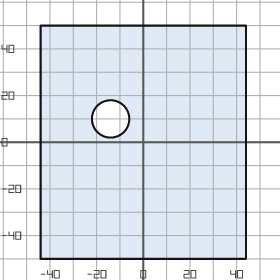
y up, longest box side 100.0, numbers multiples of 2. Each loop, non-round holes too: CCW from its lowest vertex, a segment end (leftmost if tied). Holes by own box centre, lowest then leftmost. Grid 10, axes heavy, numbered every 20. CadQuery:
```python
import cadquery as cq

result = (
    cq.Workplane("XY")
    .moveTo(-44.0, -50.0)
    .lineTo(44.0, -50.0)
    .lineTo(44.0, 50.0)
    .lineTo(-44.0, 50.0)
    .close()
    .moveTo(-14.0, 10.0)
    .circle(8.0)
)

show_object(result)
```